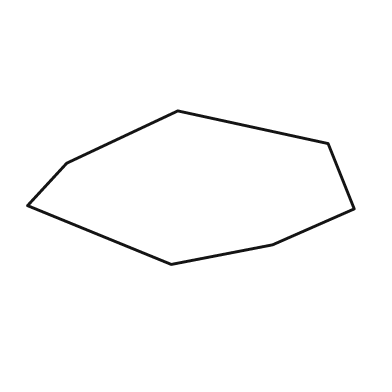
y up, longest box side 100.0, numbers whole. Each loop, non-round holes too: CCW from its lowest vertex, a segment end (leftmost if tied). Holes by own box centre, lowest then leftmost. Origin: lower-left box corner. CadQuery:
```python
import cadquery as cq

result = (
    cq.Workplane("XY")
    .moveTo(44.0, 0.0)
    .lineTo(75.0, 6.0)
    .lineTo(100.0, 17.0)
    .lineTo(92.0, 37.0)
    .lineTo(46.0, 47.0)
    .lineTo(12.0, 31.0)
    .lineTo(0.0, 18.0)
    .close()
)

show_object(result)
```